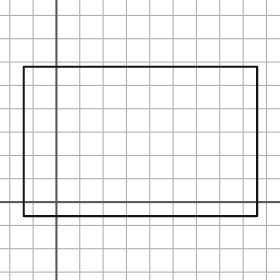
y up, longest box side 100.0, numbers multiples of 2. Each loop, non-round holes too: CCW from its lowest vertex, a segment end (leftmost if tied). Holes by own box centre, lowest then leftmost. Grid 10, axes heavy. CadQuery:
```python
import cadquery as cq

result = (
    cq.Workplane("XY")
    .moveTo(-14.0, -6.0)
    .lineTo(86.0, -6.0)
    .lineTo(86.0, 58.0)
    .lineTo(-14.0, 58.0)
    .close()
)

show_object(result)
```